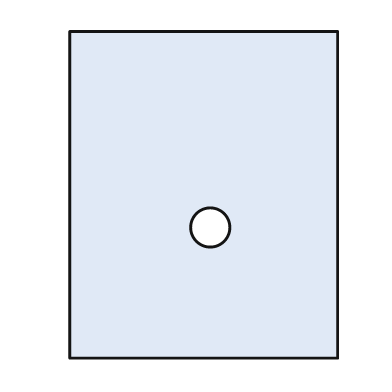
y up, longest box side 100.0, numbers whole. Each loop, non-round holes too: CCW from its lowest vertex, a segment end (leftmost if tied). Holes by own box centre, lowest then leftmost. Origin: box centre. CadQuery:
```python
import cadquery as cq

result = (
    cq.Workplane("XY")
    .moveTo(-41.0, -50.0)
    .lineTo(41.0, -50.0)
    .lineTo(41.0, 50.0)
    .lineTo(-41.0, 50.0)
    .close()
    .moveTo(2.0, -10.0)
    .circle(6.0)
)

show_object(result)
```